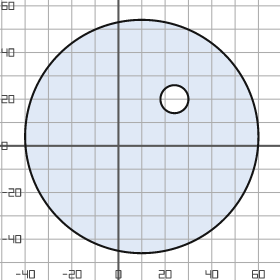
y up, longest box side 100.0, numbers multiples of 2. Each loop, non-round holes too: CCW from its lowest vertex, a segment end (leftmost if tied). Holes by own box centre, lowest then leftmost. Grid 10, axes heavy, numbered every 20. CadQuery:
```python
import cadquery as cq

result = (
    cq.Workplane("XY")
    .moveTo(10.0, 4.0)
    .circle(50.0)
    .moveTo(24.0, 20.0)
    .circle(6.0)
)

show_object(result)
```